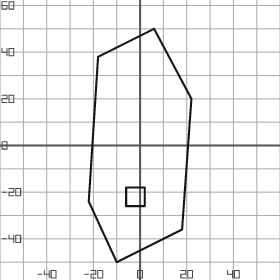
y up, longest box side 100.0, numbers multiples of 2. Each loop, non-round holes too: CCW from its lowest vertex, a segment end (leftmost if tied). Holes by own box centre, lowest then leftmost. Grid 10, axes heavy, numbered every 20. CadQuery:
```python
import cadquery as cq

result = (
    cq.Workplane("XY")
    .moveTo(-10.0, -50.0)
    .lineTo(18.0, -36.0)
    .lineTo(22.0, 20.0)
    .lineTo(6.0, 50.0)
    .lineTo(-18.0, 38.0)
    .lineTo(-22.0, -24.0)
    .close()
    .moveTo(-6.0, -26.0)
    .lineTo(2.0, -26.0)
    .lineTo(2.0, -18.0)
    .lineTo(-6.0, -18.0)
    .close()
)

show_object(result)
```